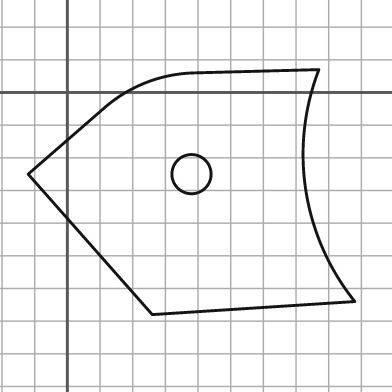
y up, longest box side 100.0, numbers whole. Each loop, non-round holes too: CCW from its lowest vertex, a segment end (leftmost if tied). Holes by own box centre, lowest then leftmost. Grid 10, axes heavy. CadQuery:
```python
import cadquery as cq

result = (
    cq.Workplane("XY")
    .moveTo(26.0, -68.0)
    .lineTo(88.0, -64.0)
    .threePointArc((73.0, -30.0), (77.0, 7.0))
    .lineTo(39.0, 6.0)
    .threePointArc((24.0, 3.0), (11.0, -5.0))
    .lineTo(-12.0, -25.0)
    .close()
    .moveTo(38.0, -25.0)
    .circle(6.0)
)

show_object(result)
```